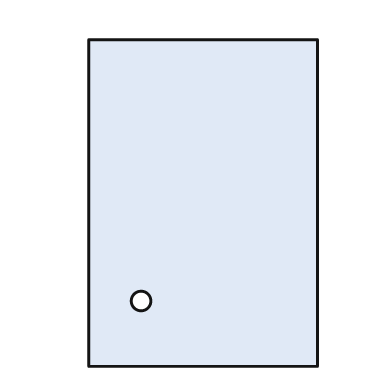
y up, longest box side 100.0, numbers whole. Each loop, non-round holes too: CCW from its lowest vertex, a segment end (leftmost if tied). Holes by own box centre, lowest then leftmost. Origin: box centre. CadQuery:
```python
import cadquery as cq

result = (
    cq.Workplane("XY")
    .moveTo(-35.0, -50.0)
    .lineTo(35.0, -50.0)
    .lineTo(35.0, 50.0)
    .lineTo(-35.0, 50.0)
    .close()
    .moveTo(-19.0, -30.0)
    .circle(3.0)
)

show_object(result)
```